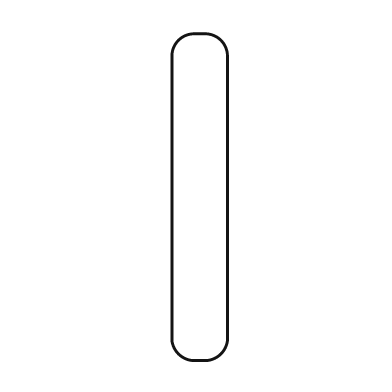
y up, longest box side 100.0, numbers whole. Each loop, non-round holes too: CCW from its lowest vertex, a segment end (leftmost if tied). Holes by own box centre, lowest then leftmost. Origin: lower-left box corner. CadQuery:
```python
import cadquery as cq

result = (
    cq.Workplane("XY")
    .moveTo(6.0, 0.0)
    .lineTo(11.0, 0.0)
    .threePointArc((15.0, 2.0), (17.0, 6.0))
    .lineTo(17.0, 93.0)
    .threePointArc((15.0, 98.0), (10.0, 100.0))
    .lineTo(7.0, 100.0)
    .threePointArc((2.0, 98.0), (0.0, 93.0))
    .lineTo(0.0, 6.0)
    .threePointArc((2.0, 2.0), (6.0, 0.0))
    .close()
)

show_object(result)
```